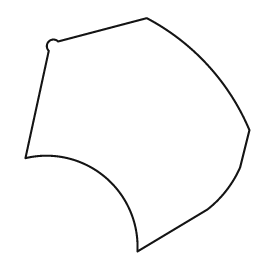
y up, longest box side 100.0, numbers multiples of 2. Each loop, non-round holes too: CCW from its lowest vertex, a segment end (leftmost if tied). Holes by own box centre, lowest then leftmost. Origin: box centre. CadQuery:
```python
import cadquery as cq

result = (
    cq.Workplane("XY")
    .moveTo(0.0, -50.0)
    .lineTo(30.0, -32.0)
    .threePointArc((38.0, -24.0), (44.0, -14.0))
    .lineTo(48.0, 2.0)
    .threePointArc((30.0, 30.0), (4.0, 50.0))
    .lineTo(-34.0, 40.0)
    .threePointArc((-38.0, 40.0), (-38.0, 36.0))
    .lineTo(-48.0, -10.0)
    .threePointArc((-14.0, -18.0), (0.0, -50.0))
    .close()
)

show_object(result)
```